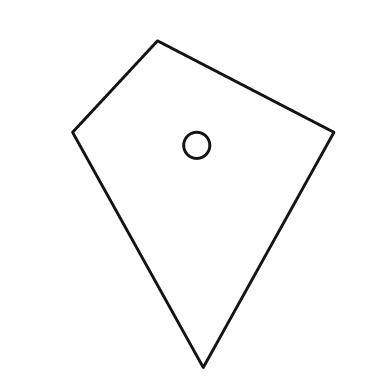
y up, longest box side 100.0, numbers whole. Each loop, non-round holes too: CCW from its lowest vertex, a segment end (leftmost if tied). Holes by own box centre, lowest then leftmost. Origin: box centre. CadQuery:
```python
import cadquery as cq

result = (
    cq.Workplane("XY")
    .moveTo(0.0, -50.0)
    .lineTo(40.0, 22.0)
    .lineTo(-14.0, 50.0)
    .lineTo(-40.0, 22.0)
    .close()
    .moveTo(-2.0, 18.0)
    .circle(4.0)
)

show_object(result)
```